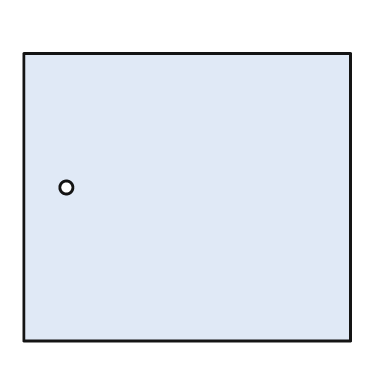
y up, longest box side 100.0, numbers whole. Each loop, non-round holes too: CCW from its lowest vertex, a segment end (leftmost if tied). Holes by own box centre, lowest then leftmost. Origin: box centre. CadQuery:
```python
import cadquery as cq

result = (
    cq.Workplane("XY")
    .moveTo(-50.0, -44.0)
    .lineTo(50.0, -44.0)
    .lineTo(50.0, 44.0)
    .lineTo(-50.0, 44.0)
    .close()
    .moveTo(-37.0, 3.0)
    .circle(2.0)
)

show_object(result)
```